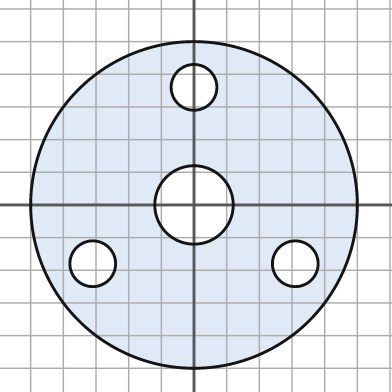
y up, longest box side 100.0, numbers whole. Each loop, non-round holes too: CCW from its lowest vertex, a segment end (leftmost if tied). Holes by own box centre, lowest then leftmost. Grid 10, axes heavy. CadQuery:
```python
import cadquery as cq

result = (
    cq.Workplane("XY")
    .moveTo(0.0, 0.0)
    .circle(50.0)
    .moveTo(-31.0, -18.0)
    .circle(7.0)
    .moveTo(31.0, -18.0)
    .circle(7.0)
    .moveTo(0.0, 0.0)
    .circle(12.0)
    .moveTo(0.0, 36.0)
    .circle(7.0)
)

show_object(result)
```